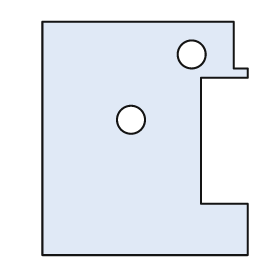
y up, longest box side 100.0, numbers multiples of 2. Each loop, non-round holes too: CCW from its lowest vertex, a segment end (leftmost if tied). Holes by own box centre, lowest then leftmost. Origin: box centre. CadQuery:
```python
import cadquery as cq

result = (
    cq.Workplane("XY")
    .moveTo(-44.0, -50.0)
    .lineTo(44.0, -50.0)
    .lineTo(44.0, -28.0)
    .lineTo(24.0, -28.0)
    .lineTo(24.0, 26.0)
    .lineTo(44.0, 26.0)
    .lineTo(44.0, 30.0)
    .lineTo(38.0, 30.0)
    .lineTo(38.0, 50.0)
    .lineTo(-44.0, 50.0)
    .close()
    .moveTo(-6.0, 8.0)
    .circle(6.0)
    .moveTo(20.0, 36.0)
    .circle(6.0)
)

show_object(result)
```